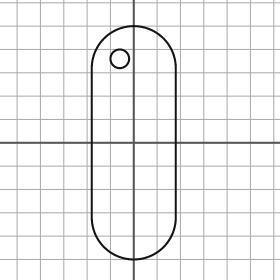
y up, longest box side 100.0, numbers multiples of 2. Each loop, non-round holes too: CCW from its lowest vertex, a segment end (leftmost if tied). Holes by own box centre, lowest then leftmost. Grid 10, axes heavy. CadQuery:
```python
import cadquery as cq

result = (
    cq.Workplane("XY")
    .moveTo(-18.0, -32.0)
    .threePointArc((0.0, -50.0), (18.0, -32.0))
    .lineTo(18.0, 32.0)
    .threePointArc((0.0, 50.0), (-18.0, 32.0))
    .close()
    .moveTo(-6.0, 36.0)
    .circle(4.0)
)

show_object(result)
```